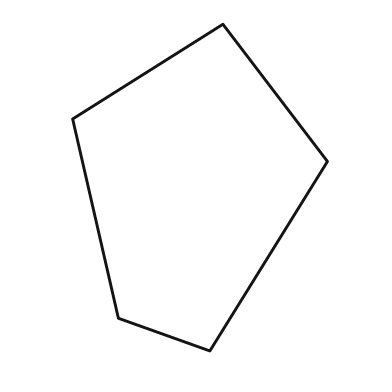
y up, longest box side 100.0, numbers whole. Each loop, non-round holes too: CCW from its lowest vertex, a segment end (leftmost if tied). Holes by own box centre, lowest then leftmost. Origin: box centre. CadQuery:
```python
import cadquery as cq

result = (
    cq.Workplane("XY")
    .moveTo(3.0, -50.0)
    .lineTo(39.0, 8.0)
    .lineTo(7.0, 50.0)
    .lineTo(-39.0, 21.0)
    .lineTo(-25.0, -40.0)
    .close()
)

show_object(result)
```